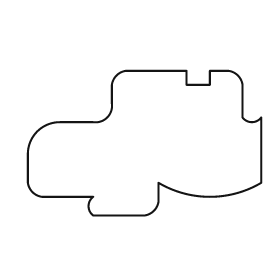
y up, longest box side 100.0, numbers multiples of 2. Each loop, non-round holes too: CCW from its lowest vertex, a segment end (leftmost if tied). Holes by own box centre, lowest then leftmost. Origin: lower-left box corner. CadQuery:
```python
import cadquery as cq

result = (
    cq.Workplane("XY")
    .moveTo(28.0, 0.0)
    .lineTo(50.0, 0.0)
    .threePointArc((54.0, 2.0), (56.0, 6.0))
    .lineTo(56.0, 14.0)
    .threePointArc((78.0, 8.0), (100.0, 14.0))
    .lineTo(100.0, 42.0)
    .threePointArc((96.0, 40.0), (92.0, 42.0))
    .lineTo(92.0, 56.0)
    .threePointArc((90.0, 60.0), (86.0, 62.0))
    .lineTo(78.0, 62.0)
    .lineTo(78.0, 56.0)
    .lineTo(68.0, 56.0)
    .lineTo(68.0, 62.0)
    .lineTo(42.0, 62.0)
    .threePointArc((38.0, 60.0), (36.0, 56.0))
    .lineTo(36.0, 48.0)
    .threePointArc((34.0, 42.0), (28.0, 40.0))
    .lineTo(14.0, 40.0)
    .threePointArc((4.0, 36.0), (0.0, 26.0))
    .lineTo(0.0, 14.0)
    .threePointArc((2.0, 10.0), (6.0, 8.0))
    .lineTo(28.0, 8.0)
    .threePointArc((26.0, 4.0), (28.0, 0.0))
    .close()
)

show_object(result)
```